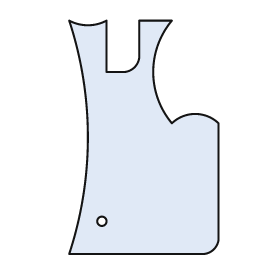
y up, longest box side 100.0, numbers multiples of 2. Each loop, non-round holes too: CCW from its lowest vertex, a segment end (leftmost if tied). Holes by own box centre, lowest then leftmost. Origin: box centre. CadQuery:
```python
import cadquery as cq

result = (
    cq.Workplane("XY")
    .moveTo(-32.0, -50.0)
    .lineTo(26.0, -50.0)
    .threePointArc((30.0, -48.0), (32.0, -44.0))
    .lineTo(32.0, 6.0)
    .threePointArc((22.0, 10.0), (12.0, 6.0))
    .threePointArc((4.0, 28.0), (12.0, 50.0))
    .lineTo(-2.0, 50.0)
    .lineTo(-2.0, 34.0)
    .threePointArc((-4.0, 30.0), (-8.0, 28.0))
    .lineTo(-16.0, 28.0)
    .lineTo(-16.0, 50.0)
    .threePointArc((-24.0, 48.0), (-32.0, 50.0))
    .threePointArc((-24.0, 0.0), (-32.0, -50.0))
    .close()
    .moveTo(-18.0, -36.0)
    .circle(2.0)
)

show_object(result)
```